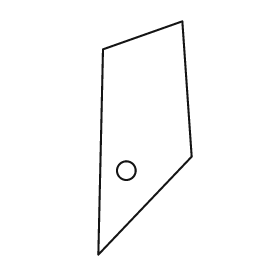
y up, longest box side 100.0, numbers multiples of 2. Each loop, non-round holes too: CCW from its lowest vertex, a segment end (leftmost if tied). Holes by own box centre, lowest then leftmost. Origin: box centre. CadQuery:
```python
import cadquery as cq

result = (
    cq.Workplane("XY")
    .moveTo(-20.0, -50.0)
    .lineTo(20.0, -8.0)
    .lineTo(16.0, 50.0)
    .lineTo(-18.0, 38.0)
    .close()
    .moveTo(-8.0, -14.0)
    .circle(4.0)
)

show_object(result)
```